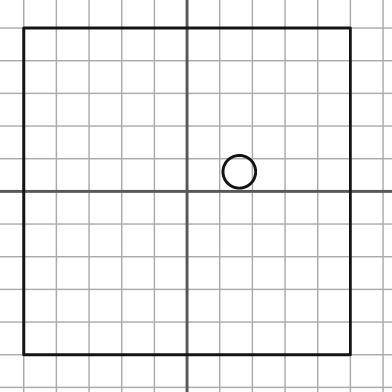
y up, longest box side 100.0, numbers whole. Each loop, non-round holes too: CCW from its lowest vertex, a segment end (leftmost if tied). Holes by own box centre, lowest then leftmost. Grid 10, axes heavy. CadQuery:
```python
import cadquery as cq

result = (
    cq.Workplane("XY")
    .moveTo(-50.0, -50.0)
    .lineTo(50.0, -50.0)
    .lineTo(50.0, 50.0)
    .lineTo(-50.0, 50.0)
    .close()
    .moveTo(16.0, 6.0)
    .circle(5.0)
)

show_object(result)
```